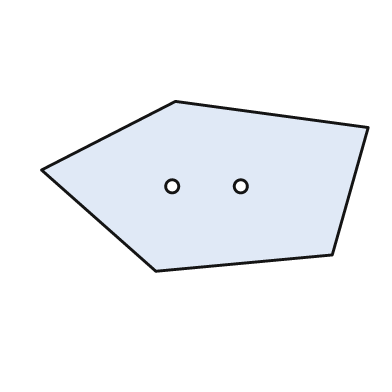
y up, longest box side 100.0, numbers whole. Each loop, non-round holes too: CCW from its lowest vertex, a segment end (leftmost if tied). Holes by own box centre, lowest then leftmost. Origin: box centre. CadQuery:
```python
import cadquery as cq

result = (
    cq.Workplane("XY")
    .moveTo(-15.0, -26.0)
    .lineTo(39.0, -21.0)
    .lineTo(50.0, 18.0)
    .lineTo(-9.0, 26.0)
    .lineTo(-50.0, 5.0)
    .close()
    .moveTo(-10.0, 0.0)
    .circle(2.0)
    .moveTo(11.0, 0.0)
    .circle(2.0)
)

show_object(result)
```